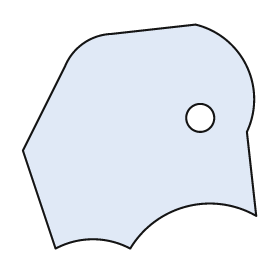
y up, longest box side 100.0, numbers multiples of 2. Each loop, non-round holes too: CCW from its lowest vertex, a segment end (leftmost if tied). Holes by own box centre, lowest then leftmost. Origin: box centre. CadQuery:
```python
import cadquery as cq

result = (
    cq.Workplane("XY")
    .moveTo(-36.0, -48.0)
    .threePointArc((-20.0, -44.0), (-4.0, -48.0))
    .threePointArc((20.0, -30.0), (50.0, -34.0))
    .lineTo(46.0, 2.0)
    .threePointArc((46.0, 30.0), (24.0, 48.0))
    .lineTo(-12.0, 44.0)
    .threePointArc((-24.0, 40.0), (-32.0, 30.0))
    .lineTo(-50.0, -6.0)
    .close()
    .moveTo(26.0, 8.0)
    .circle(6.0)
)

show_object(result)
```